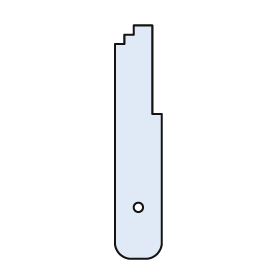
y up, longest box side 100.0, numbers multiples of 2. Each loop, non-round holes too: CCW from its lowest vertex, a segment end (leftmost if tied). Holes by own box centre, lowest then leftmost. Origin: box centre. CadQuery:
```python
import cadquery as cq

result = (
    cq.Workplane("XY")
    .moveTo(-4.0, -50.0)
    .lineTo(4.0, -50.0)
    .threePointArc((8.0, -48.0), (10.0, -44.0))
    .lineTo(10.0, 12.0)
    .lineTo(6.0, 12.0)
    .lineTo(6.0, 50.0)
    .lineTo(-2.0, 50.0)
    .lineTo(-2.0, 46.0)
    .lineTo(-6.0, 46.0)
    .lineTo(-6.0, 42.0)
    .lineTo(-10.0, 42.0)
    .lineTo(-10.0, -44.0)
    .threePointArc((-8.0, -48.0), (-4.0, -50.0))
    .close()
    .moveTo(0.0, -28.0)
    .circle(2.0)
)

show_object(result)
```